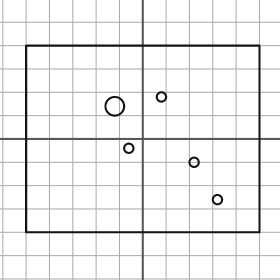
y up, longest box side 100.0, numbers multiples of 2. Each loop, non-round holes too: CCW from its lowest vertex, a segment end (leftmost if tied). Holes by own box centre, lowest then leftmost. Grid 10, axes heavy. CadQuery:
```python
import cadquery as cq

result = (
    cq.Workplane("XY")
    .moveTo(-50.0, -40.0)
    .lineTo(50.0, -40.0)
    .lineTo(50.0, 40.0)
    .lineTo(-50.0, 40.0)
    .close()
    .moveTo(32.0, -26.0)
    .circle(2.0)
    .moveTo(22.0, -10.0)
    .circle(2.0)
    .moveTo(-6.0, -4.0)
    .circle(2.0)
    .moveTo(-12.0, 14.0)
    .circle(4.0)
    .moveTo(8.0, 18.0)
    .circle(2.0)
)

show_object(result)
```